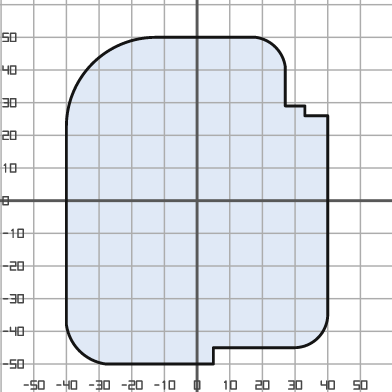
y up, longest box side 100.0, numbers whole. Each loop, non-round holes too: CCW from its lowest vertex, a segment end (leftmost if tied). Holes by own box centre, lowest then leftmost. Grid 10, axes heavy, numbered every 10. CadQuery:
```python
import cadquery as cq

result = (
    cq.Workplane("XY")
    .moveTo(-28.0, -50.0)
    .lineTo(5.0, -50.0)
    .lineTo(5.0, -45.0)
    .lineTo(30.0, -45.0)
    .threePointArc((37.0, -42.0), (40.0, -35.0))
    .lineTo(40.0, 26.0)
    .lineTo(33.0, 26.0)
    .lineTo(33.0, 29.0)
    .lineTo(27.0, 29.0)
    .lineTo(27.0, 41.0)
    .threePointArc((24.0, 47.0), (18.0, 50.0))
    .lineTo(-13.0, 50.0)
    .threePointArc((-32.0, 42.0), (-40.0, 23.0))
    .lineTo(-40.0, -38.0)
    .threePointArc((-36.0, -46.0), (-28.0, -50.0))
    .close()
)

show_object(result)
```